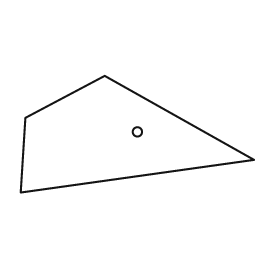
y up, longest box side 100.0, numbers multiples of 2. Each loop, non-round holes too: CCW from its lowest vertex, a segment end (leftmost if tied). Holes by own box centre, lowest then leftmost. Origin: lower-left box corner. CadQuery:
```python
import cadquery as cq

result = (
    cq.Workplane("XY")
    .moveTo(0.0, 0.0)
    .lineTo(100.0, 14.0)
    .lineTo(36.0, 50.0)
    .lineTo(2.0, 32.0)
    .close()
    .moveTo(50.0, 26.0)
    .circle(2.0)
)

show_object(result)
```